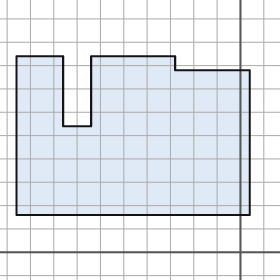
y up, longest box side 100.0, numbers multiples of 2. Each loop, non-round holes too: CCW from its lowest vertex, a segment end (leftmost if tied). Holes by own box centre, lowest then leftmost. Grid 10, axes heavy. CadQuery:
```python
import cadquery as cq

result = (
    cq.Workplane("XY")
    .moveTo(-96.0, 16.0)
    .lineTo(4.0, 16.0)
    .lineTo(4.0, 78.0)
    .lineTo(-28.0, 78.0)
    .lineTo(-28.0, 84.0)
    .lineTo(-64.0, 84.0)
    .lineTo(-64.0, 54.0)
    .lineTo(-76.0, 54.0)
    .lineTo(-76.0, 84.0)
    .lineTo(-96.0, 84.0)
    .close()
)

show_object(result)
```